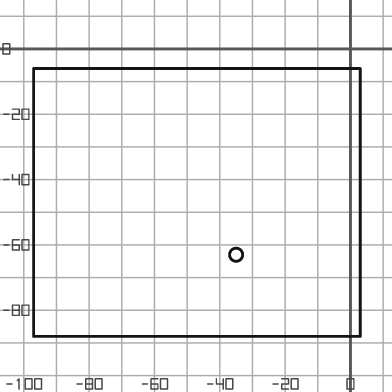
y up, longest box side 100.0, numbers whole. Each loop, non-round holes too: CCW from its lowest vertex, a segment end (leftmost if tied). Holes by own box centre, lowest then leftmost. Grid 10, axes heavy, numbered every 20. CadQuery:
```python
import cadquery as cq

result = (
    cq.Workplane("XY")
    .moveTo(-97.0, -88.0)
    .lineTo(3.0, -88.0)
    .lineTo(3.0, -6.0)
    .lineTo(-97.0, -6.0)
    .close()
    .moveTo(-35.0, -63.0)
    .circle(2.0)
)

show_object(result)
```